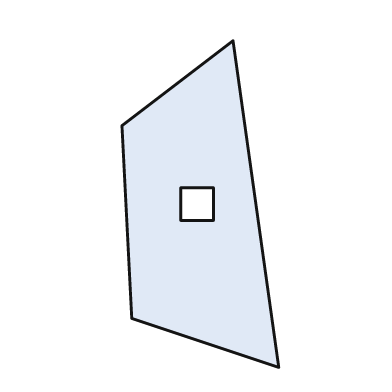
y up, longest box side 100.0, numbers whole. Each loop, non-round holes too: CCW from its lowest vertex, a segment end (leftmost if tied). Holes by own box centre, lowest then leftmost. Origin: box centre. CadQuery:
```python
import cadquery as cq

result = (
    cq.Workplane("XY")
    .moveTo(24.0, -50.0)
    .lineTo(10.0, 50.0)
    .lineTo(-24.0, 24.0)
    .lineTo(-21.0, -35.0)
    .close()
    .moveTo(-6.0, -5.0)
    .lineTo(4.0, -5.0)
    .lineTo(4.0, 5.0)
    .lineTo(-6.0, 5.0)
    .close()
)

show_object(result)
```